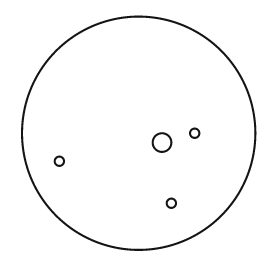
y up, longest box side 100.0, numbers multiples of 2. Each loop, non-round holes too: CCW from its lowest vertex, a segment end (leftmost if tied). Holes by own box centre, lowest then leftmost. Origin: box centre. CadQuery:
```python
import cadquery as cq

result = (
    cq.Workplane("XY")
    .moveTo(0.0, 0.0)
    .circle(50.0)
    .moveTo(14.0, -30.0)
    .circle(2.0)
    .moveTo(-34.0, -12.0)
    .circle(2.0)
    .moveTo(10.0, -4.0)
    .circle(4.0)
    .moveTo(24.0, 0.0)
    .circle(2.0)
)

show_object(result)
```